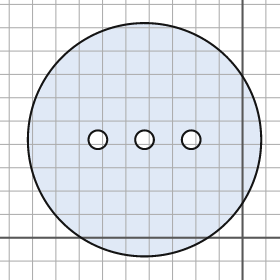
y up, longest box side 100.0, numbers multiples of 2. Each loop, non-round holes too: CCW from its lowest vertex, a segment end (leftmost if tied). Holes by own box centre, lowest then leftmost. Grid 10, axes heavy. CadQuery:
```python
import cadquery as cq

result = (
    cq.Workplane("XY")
    .moveTo(-42.0, 42.0)
    .circle(50.0)
    .moveTo(-62.0, 42.0)
    .circle(4.0)
    .moveTo(-42.0, 42.0)
    .circle(4.0)
    .moveTo(-22.0, 42.0)
    .circle(4.0)
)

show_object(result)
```